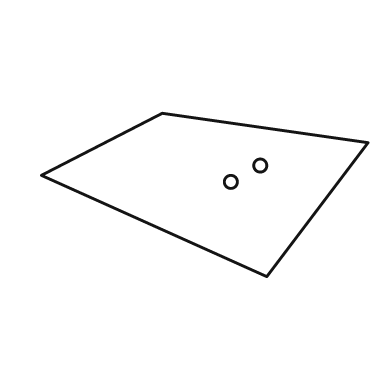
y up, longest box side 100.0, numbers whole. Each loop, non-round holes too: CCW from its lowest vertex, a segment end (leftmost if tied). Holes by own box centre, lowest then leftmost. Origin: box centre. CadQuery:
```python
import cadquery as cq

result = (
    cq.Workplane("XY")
    .moveTo(19.0, -25.0)
    .lineTo(50.0, 16.0)
    .lineTo(-13.0, 25.0)
    .lineTo(-50.0, 6.0)
    .close()
    .moveTo(8.0, 4.0)
    .circle(2.0)
    .moveTo(17.0, 9.0)
    .circle(2.0)
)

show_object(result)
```